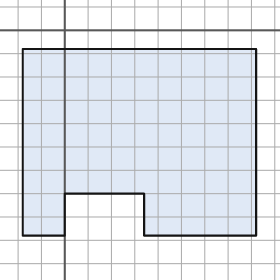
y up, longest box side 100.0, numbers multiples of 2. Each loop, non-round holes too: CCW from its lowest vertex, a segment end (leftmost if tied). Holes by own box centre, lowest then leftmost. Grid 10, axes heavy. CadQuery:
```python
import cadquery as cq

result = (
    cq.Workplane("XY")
    .moveTo(-18.0, -88.0)
    .lineTo(0.0, -88.0)
    .lineTo(0.0, -70.0)
    .lineTo(34.0, -70.0)
    .lineTo(34.0, -88.0)
    .lineTo(82.0, -88.0)
    .lineTo(82.0, -8.0)
    .lineTo(-18.0, -8.0)
    .close()
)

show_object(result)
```